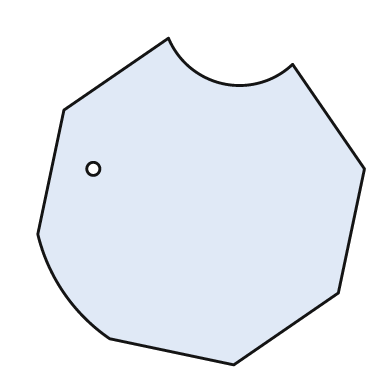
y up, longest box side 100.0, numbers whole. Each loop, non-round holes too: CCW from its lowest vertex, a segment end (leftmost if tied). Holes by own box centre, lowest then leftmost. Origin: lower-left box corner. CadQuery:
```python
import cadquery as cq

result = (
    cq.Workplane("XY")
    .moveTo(60.0, 0.0)
    .lineTo(92.0, 22.0)
    .lineTo(100.0, 60.0)
    .lineTo(78.0, 92.0)
    .threePointArc((57.0, 86.0), (40.0, 100.0))
    .lineTo(8.0, 78.0)
    .lineTo(0.0, 40.0)
    .threePointArc((8.0, 22.0), (22.0, 8.0))
    .close()
    .moveTo(17.0, 60.0)
    .circle(2.0)
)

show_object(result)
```